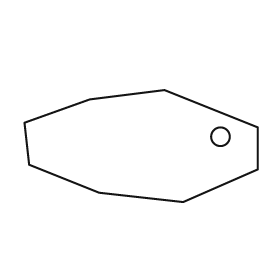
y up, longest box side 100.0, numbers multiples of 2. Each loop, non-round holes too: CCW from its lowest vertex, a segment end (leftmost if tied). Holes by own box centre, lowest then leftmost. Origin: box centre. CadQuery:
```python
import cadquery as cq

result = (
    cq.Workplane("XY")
    .moveTo(18.0, -24.0)
    .lineTo(50.0, -10.0)
    .lineTo(50.0, 8.0)
    .lineTo(10.0, 24.0)
    .lineTo(-22.0, 20.0)
    .lineTo(-50.0, 10.0)
    .lineTo(-48.0, -8.0)
    .lineTo(-18.0, -20.0)
    .close()
    .moveTo(34.0, 4.0)
    .circle(4.0)
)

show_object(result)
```